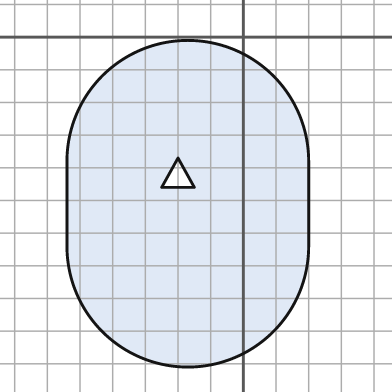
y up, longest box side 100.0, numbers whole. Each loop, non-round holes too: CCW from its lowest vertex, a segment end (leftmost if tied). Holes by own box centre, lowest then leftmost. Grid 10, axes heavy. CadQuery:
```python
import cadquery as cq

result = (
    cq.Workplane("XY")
    .moveTo(-54.0, -64.0)
    .threePointArc((-17.0, -101.0), (20.0, -64.0))
    .lineTo(20.0, -38.0)
    .threePointArc((-17.0, -1.0), (-54.0, -38.0))
    .close()
    .moveTo(-25.0, -46.0)
    .lineTo(-15.0, -46.0)
    .lineTo(-20.0, -37.0)
    .close()
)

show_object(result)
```